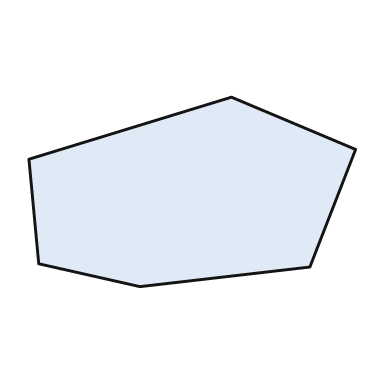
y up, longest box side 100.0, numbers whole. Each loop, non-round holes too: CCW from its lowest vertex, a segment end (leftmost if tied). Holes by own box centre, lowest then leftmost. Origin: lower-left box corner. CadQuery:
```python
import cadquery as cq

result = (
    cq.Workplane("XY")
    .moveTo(34.0, 0.0)
    .lineTo(86.0, 6.0)
    .lineTo(100.0, 42.0)
    .lineTo(62.0, 58.0)
    .lineTo(0.0, 39.0)
    .lineTo(3.0, 7.0)
    .close()
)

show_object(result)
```